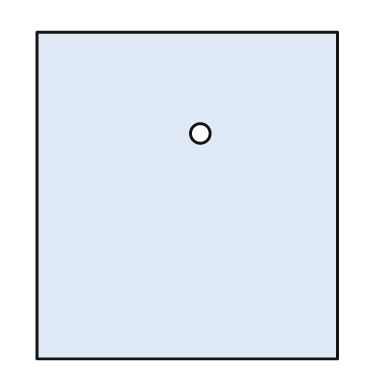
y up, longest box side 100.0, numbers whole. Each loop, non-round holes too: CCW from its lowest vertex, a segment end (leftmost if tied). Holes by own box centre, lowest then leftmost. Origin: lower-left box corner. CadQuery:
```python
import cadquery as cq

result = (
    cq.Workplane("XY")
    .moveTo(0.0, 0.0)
    .lineTo(92.0, 0.0)
    .lineTo(92.0, 100.0)
    .lineTo(0.0, 100.0)
    .close()
    .moveTo(50.0, 69.0)
    .circle(3.0)
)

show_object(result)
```